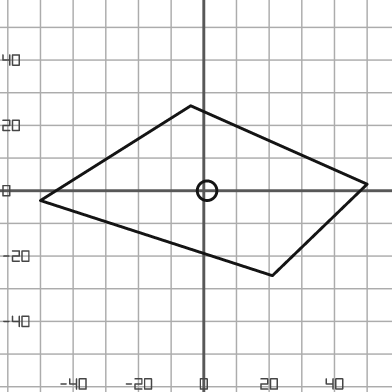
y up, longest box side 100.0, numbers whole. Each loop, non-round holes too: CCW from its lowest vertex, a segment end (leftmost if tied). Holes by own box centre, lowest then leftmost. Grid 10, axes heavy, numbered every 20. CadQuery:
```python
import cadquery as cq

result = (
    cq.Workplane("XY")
    .moveTo(21.0, -26.0)
    .lineTo(50.0, 2.0)
    .lineTo(-4.0, 26.0)
    .lineTo(-50.0, -3.0)
    .close()
    .moveTo(1.0, 0.0)
    .circle(3.0)
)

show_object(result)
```